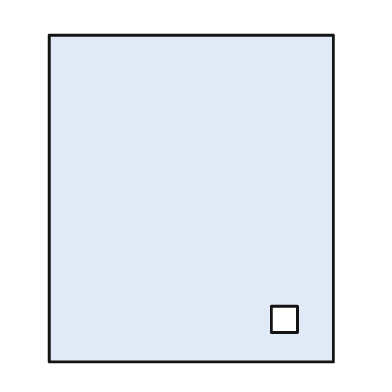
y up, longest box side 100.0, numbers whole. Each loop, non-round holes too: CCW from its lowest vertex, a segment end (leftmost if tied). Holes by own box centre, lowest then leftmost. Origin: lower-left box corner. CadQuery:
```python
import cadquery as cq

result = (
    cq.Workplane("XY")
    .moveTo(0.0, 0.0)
    .lineTo(87.0, 0.0)
    .lineTo(87.0, 100.0)
    .lineTo(0.0, 100.0)
    .close()
    .moveTo(68.0, 9.0)
    .lineTo(76.0, 9.0)
    .lineTo(76.0, 17.0)
    .lineTo(68.0, 17.0)
    .close()
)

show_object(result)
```